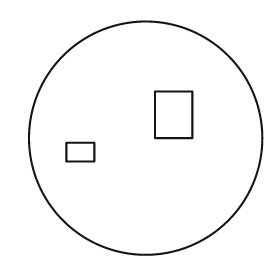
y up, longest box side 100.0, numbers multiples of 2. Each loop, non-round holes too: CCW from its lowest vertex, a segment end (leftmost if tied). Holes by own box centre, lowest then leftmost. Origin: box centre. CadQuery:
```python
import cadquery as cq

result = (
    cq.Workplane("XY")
    .moveTo(0.0, 0.0)
    .circle(50.0)
    .moveTo(-34.0, -10.0)
    .lineTo(-22.0, -10.0)
    .lineTo(-22.0, -2.0)
    .lineTo(-34.0, -2.0)
    .close()
    .moveTo(4.0, 0.0)
    .lineTo(20.0, 0.0)
    .lineTo(20.0, 20.0)
    .lineTo(4.0, 20.0)
    .close()
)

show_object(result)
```